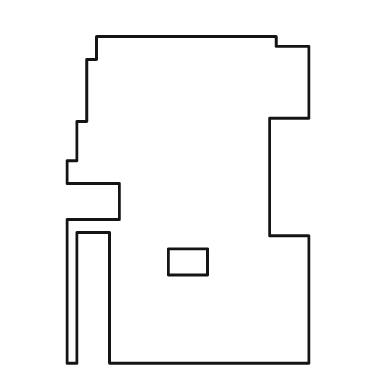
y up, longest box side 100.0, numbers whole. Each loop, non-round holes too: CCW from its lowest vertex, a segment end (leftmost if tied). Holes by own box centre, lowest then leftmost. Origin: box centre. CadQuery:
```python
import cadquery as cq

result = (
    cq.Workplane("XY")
    .moveTo(-37.0, -50.0)
    .lineTo(-34.0, -50.0)
    .lineTo(-34.0, -10.0)
    .lineTo(-24.0, -10.0)
    .lineTo(-24.0, -50.0)
    .lineTo(37.0, -50.0)
    .lineTo(37.0, -11.0)
    .lineTo(25.0, -11.0)
    .lineTo(25.0, 25.0)
    .lineTo(37.0, 25.0)
    .lineTo(37.0, 47.0)
    .lineTo(27.0, 47.0)
    .lineTo(27.0, 50.0)
    .lineTo(-28.0, 50.0)
    .lineTo(-28.0, 43.0)
    .lineTo(-31.0, 43.0)
    .lineTo(-31.0, 24.0)
    .lineTo(-34.0, 24.0)
    .lineTo(-34.0, 12.0)
    .lineTo(-37.0, 12.0)
    .lineTo(-37.0, 5.0)
    .lineTo(-21.0, 5.0)
    .lineTo(-21.0, -6.0)
    .lineTo(-37.0, -6.0)
    .close()
    .moveTo(-6.0, -23.0)
    .lineTo(6.0, -23.0)
    .lineTo(6.0, -15.0)
    .lineTo(-6.0, -15.0)
    .close()
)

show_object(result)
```